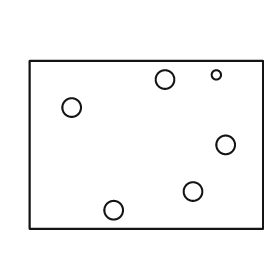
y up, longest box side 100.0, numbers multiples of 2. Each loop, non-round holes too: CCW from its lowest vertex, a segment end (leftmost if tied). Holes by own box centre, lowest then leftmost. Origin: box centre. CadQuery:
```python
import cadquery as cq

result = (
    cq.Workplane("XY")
    .moveTo(-50.0, -36.0)
    .lineTo(50.0, -36.0)
    .lineTo(50.0, 36.0)
    .lineTo(-50.0, 36.0)
    .close()
    .moveTo(-14.0, -28.0)
    .circle(4.0)
    .moveTo(20.0, -20.0)
    .circle(4.0)
    .moveTo(34.0, 0.0)
    .circle(4.0)
    .moveTo(-32.0, 16.0)
    .circle(4.0)
    .moveTo(8.0, 28.0)
    .circle(4.0)
    .moveTo(30.0, 30.0)
    .circle(2.0)
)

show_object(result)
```